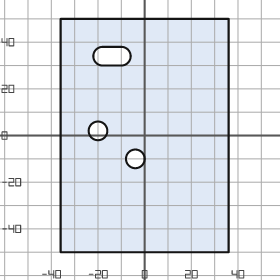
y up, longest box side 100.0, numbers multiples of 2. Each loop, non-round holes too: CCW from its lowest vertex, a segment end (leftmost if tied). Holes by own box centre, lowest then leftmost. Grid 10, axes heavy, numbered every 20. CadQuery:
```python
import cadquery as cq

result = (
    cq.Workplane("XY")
    .moveTo(-36.0, -50.0)
    .lineTo(36.0, -50.0)
    .lineTo(36.0, 50.0)
    .lineTo(-36.0, 50.0)
    .close()
    .moveTo(-4.0, -10.0)
    .circle(4.0)
    .moveTo(-20.0, 2.0)
    .circle(4.0)
    .moveTo(-18.0, 30.0)
    .lineTo(-10.0, 30.0)
    .threePointArc((-6.0, 34.0), (-10.0, 38.0))
    .lineTo(-18.0, 38.0)
    .threePointArc((-22.0, 34.0), (-18.0, 30.0))
    .close()
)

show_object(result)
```